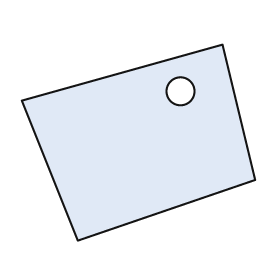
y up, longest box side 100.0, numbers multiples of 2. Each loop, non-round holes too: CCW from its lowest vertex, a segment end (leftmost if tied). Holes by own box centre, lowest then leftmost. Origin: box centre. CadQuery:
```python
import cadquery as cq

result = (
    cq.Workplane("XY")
    .moveTo(-26.0, -42.0)
    .lineTo(50.0, -16.0)
    .lineTo(36.0, 42.0)
    .lineTo(-50.0, 18.0)
    .close()
    .moveTo(18.0, 22.0)
    .circle(6.0)
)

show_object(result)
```